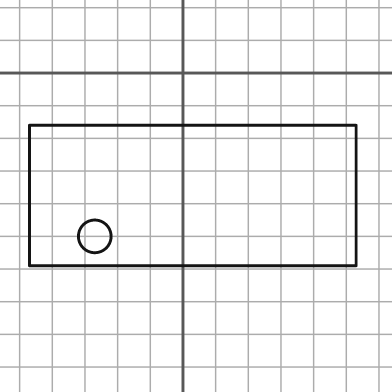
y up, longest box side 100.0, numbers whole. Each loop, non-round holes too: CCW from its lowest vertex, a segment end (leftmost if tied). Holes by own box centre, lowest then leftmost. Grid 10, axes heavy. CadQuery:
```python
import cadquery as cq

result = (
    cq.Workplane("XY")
    .moveTo(-47.0, -59.0)
    .lineTo(53.0, -59.0)
    .lineTo(53.0, -16.0)
    .lineTo(-47.0, -16.0)
    .close()
    .moveTo(-27.0, -50.0)
    .circle(5.0)
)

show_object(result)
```